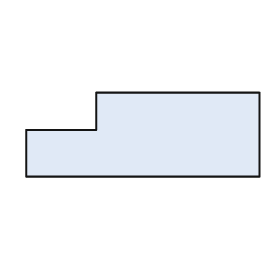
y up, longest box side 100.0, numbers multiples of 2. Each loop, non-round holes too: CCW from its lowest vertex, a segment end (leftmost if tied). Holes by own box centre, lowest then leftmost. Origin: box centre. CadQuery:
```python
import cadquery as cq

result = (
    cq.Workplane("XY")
    .moveTo(-50.0, -18.0)
    .lineTo(50.0, -18.0)
    .lineTo(50.0, 18.0)
    .lineTo(-20.0, 18.0)
    .lineTo(-20.0, 2.0)
    .lineTo(-50.0, 2.0)
    .close()
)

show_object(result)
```